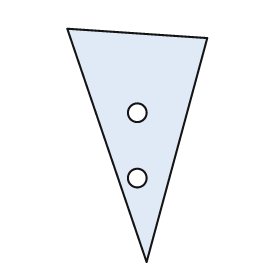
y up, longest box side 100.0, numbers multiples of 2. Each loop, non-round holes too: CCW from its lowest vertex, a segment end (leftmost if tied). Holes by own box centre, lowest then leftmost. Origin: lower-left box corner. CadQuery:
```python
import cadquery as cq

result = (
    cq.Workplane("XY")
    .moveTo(34.0, 0.0)
    .lineTo(60.0, 96.0)
    .lineTo(0.0, 100.0)
    .close()
    .moveTo(30.0, 36.0)
    .circle(4.0)
    .moveTo(30.0, 64.0)
    .circle(4.0)
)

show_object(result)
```